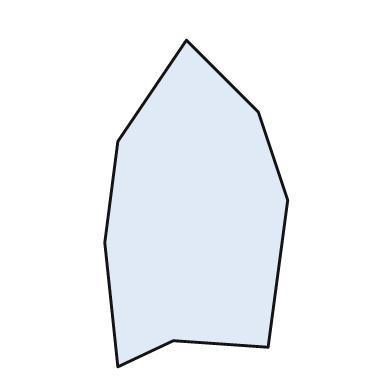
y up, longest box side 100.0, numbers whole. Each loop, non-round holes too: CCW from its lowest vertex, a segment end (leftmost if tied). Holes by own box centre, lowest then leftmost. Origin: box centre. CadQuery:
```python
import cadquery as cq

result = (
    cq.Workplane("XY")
    .moveTo(-24.0, -50.0)
    .lineTo(-7.0, -42.0)
    .lineTo(22.0, -44.0)
    .lineTo(28.0, 1.0)
    .lineTo(19.0, 28.0)
    .lineTo(-3.0, 50.0)
    .lineTo(-24.0, 19.0)
    .lineTo(-28.0, -12.0)
    .close()
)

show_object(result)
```